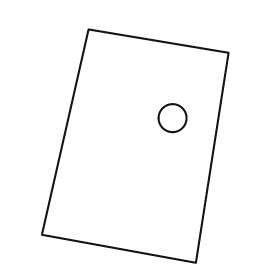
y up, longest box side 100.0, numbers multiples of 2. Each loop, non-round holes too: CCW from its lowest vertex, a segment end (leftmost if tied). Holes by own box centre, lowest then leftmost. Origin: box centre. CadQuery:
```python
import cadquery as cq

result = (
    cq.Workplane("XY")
    .moveTo(26.0, -50.0)
    .lineTo(40.0, 40.0)
    .lineTo(-20.0, 50.0)
    .lineTo(-40.0, -38.0)
    .close()
    .moveTo(16.0, 12.0)
    .circle(6.0)
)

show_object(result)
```